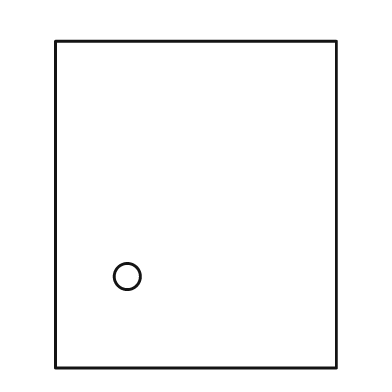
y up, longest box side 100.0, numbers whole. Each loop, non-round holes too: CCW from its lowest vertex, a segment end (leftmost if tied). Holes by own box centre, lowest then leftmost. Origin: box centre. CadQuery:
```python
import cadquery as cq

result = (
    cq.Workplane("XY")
    .moveTo(-43.0, -50.0)
    .lineTo(43.0, -50.0)
    .lineTo(43.0, 50.0)
    .lineTo(-43.0, 50.0)
    .close()
    .moveTo(-21.0, -22.0)
    .circle(4.0)
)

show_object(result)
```